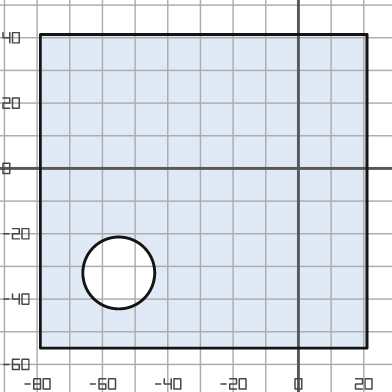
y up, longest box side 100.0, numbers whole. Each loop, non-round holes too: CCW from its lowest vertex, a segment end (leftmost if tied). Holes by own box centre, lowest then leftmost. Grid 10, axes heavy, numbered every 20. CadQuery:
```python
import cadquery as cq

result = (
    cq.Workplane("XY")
    .moveTo(-79.0, -55.0)
    .lineTo(21.0, -55.0)
    .lineTo(21.0, 41.0)
    .lineTo(-79.0, 41.0)
    .close()
    .moveTo(-55.0, -32.0)
    .circle(11.0)
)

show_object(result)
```